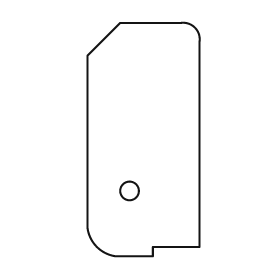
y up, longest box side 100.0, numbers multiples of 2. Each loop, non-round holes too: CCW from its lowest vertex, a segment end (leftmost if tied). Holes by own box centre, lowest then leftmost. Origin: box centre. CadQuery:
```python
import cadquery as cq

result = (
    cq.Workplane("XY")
    .moveTo(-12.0, -50.0)
    .lineTo(4.0, -50.0)
    .lineTo(4.0, -46.0)
    .lineTo(24.0, -46.0)
    .lineTo(24.0, 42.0)
    .threePointArc((22.0, 48.0), (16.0, 50.0))
    .lineTo(-10.0, 50.0)
    .lineTo(-24.0, 36.0)
    .lineTo(-24.0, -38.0)
    .threePointArc((-20.0, -46.0), (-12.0, -50.0))
    .close()
    .moveTo(-6.0, -22.0)
    .circle(4.0)
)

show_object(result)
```